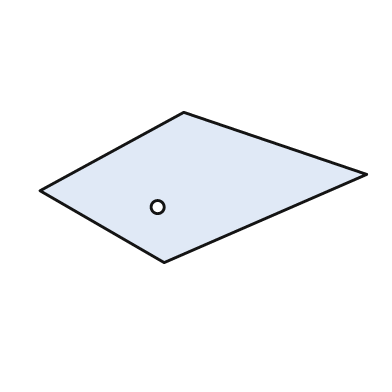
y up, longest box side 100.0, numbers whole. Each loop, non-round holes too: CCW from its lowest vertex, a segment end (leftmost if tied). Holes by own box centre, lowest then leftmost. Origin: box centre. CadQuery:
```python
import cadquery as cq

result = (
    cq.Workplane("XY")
    .moveTo(-12.0, -23.0)
    .lineTo(50.0, 4.0)
    .lineTo(-6.0, 23.0)
    .lineTo(-50.0, -1.0)
    .close()
    .moveTo(-14.0, -6.0)
    .circle(2.0)
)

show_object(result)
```